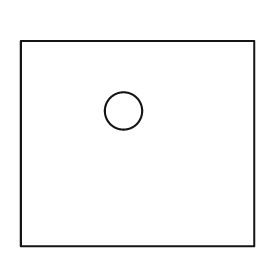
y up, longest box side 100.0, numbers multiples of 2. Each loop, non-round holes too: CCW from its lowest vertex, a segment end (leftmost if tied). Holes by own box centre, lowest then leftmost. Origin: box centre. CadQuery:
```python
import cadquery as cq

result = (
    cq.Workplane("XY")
    .moveTo(-50.0, -44.0)
    .lineTo(50.0, -44.0)
    .lineTo(50.0, 44.0)
    .lineTo(-50.0, 44.0)
    .close()
    .moveTo(-6.0, 14.0)
    .circle(8.0)
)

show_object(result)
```